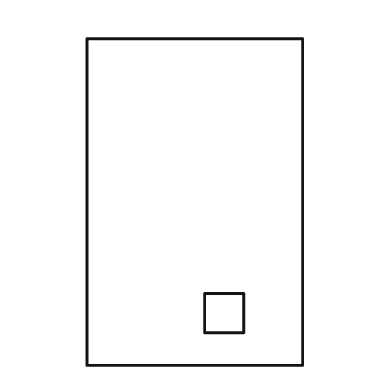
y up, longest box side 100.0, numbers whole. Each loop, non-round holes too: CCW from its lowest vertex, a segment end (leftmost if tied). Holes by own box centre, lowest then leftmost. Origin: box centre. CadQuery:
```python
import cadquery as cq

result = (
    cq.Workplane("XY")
    .moveTo(-33.0, -50.0)
    .lineTo(33.0, -50.0)
    .lineTo(33.0, 50.0)
    .lineTo(-33.0, 50.0)
    .close()
    .moveTo(3.0, -40.0)
    .lineTo(15.0, -40.0)
    .lineTo(15.0, -28.0)
    .lineTo(3.0, -28.0)
    .close()
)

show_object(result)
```